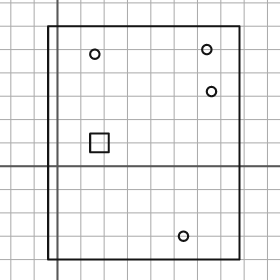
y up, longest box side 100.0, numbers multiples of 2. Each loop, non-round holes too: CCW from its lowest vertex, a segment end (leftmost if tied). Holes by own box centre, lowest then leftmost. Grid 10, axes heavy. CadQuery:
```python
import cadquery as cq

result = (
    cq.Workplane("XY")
    .moveTo(-4.0, -40.0)
    .lineTo(78.0, -40.0)
    .lineTo(78.0, 60.0)
    .lineTo(-4.0, 60.0)
    .close()
    .moveTo(54.0, -30.0)
    .circle(2.0)
    .moveTo(14.0, 6.0)
    .lineTo(22.0, 6.0)
    .lineTo(22.0, 14.0)
    .lineTo(14.0, 14.0)
    .close()
    .moveTo(66.0, 32.0)
    .circle(2.0)
    .moveTo(16.0, 48.0)
    .circle(2.0)
    .moveTo(64.0, 50.0)
    .circle(2.0)
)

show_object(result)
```